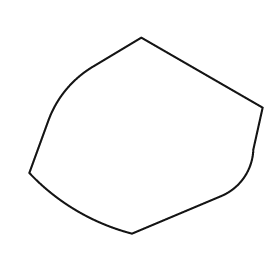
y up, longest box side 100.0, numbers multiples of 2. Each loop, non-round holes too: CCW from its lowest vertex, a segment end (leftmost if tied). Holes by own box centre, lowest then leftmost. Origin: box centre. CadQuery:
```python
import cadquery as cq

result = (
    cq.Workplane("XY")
    .moveTo(-6.0, -42.0)
    .lineTo(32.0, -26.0)
    .threePointArc((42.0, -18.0), (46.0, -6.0))
    .lineTo(50.0, 12.0)
    .lineTo(-2.0, 42.0)
    .lineTo(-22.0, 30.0)
    .threePointArc((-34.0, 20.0), (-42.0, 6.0))
    .lineTo(-50.0, -16.0)
    .threePointArc((-30.0, -32.0), (-6.0, -42.0))
    .close()
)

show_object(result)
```